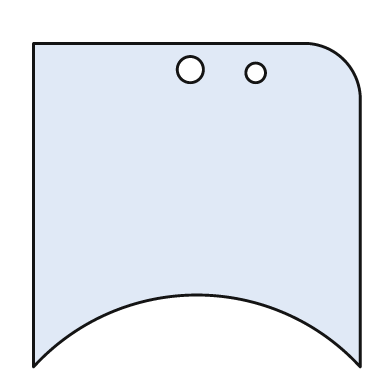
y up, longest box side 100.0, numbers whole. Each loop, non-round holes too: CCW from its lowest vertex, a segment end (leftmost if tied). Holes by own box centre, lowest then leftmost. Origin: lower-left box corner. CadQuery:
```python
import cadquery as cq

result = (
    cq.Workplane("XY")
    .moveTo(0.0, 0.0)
    .threePointArc((50.0, 22.0), (100.0, 0.0))
    .lineTo(100.0, 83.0)
    .threePointArc((95.0, 94.0), (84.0, 99.0))
    .lineTo(0.0, 99.0)
    .close()
    .moveTo(68.0, 90.0)
    .circle(3.0)
    .moveTo(48.0, 91.0)
    .circle(4.0)
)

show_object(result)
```